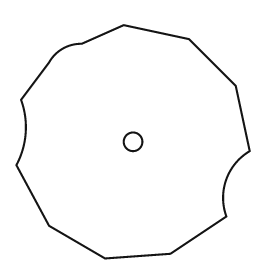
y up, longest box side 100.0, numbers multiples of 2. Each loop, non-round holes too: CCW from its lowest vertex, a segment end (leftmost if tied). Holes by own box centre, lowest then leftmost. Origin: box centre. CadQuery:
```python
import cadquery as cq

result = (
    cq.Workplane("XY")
    .moveTo(-12.0, -50.0)
    .lineTo(16.0, -48.0)
    .lineTo(40.0, -32.0)
    .threePointArc((40.0, -16.0), (50.0, -4.0))
    .lineTo(44.0, 24.0)
    .lineTo(24.0, 44.0)
    .lineTo(-4.0, 50.0)
    .lineTo(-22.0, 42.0)
    .threePointArc((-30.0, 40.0), (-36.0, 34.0))
    .lineTo(-48.0, 18.0)
    .threePointArc((-46.0, 4.0), (-50.0, -10.0))
    .lineTo(-36.0, -36.0)
    .close()
    .moveTo(0.0, 0.0)
    .circle(4.0)
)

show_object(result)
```